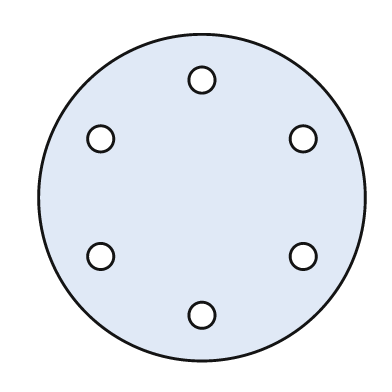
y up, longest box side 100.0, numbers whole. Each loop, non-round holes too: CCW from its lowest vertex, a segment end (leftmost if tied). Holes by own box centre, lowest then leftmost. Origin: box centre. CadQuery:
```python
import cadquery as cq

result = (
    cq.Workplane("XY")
    .moveTo(0.0, 0.0)
    .circle(50.0)
    .moveTo(0.0, -36.0)
    .circle(4.0)
    .moveTo(-31.0, -18.0)
    .circle(4.0)
    .moveTo(31.0, -18.0)
    .circle(4.0)
    .moveTo(-31.0, 18.0)
    .circle(4.0)
    .moveTo(31.0, 18.0)
    .circle(4.0)
    .moveTo(0.0, 36.0)
    .circle(4.0)
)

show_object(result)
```